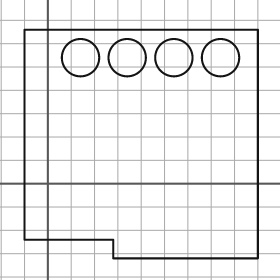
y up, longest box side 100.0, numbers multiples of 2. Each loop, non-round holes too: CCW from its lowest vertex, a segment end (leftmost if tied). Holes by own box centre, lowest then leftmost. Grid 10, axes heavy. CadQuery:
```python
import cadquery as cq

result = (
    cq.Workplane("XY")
    .moveTo(28.0, -32.0)
    .lineTo(90.0, -32.0)
    .lineTo(90.0, 66.0)
    .lineTo(-10.0, 66.0)
    .lineTo(-10.0, -24.0)
    .lineTo(28.0, -24.0)
    .close()
    .moveTo(14.0, 54.0)
    .circle(8.0)
    .moveTo(34.0, 54.0)
    .circle(8.0)
    .moveTo(54.0, 54.0)
    .circle(8.0)
    .moveTo(74.0, 54.0)
    .circle(8.0)
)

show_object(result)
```